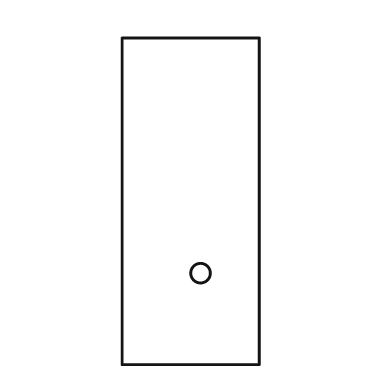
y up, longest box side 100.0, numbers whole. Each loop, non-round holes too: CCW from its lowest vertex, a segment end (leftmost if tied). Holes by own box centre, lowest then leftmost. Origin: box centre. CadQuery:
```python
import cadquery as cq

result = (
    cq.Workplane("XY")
    .moveTo(-21.0, -50.0)
    .lineTo(21.0, -50.0)
    .lineTo(21.0, 50.0)
    .lineTo(-21.0, 50.0)
    .close()
    .moveTo(3.0, -22.0)
    .circle(3.0)
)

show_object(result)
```